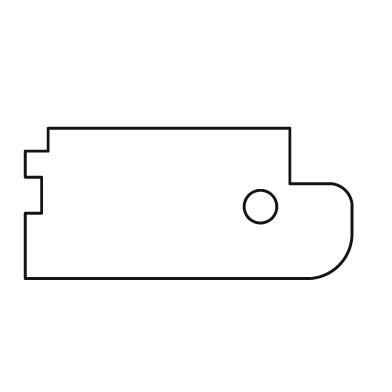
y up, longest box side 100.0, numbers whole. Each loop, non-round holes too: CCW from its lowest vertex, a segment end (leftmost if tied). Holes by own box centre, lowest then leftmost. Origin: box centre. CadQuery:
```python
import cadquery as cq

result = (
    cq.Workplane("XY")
    .moveTo(-50.0, -23.0)
    .lineTo(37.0, -23.0)
    .threePointArc((46.0, -19.0), (50.0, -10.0))
    .lineTo(50.0, 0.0)
    .threePointArc((48.0, 4.0), (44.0, 6.0))
    .lineTo(31.0, 6.0)
    .lineTo(31.0, 23.0)
    .lineTo(-43.0, 23.0)
    .lineTo(-43.0, 16.0)
    .lineTo(-50.0, 16.0)
    .lineTo(-50.0, 8.0)
    .lineTo(-45.0, 8.0)
    .lineTo(-45.0, -3.0)
    .lineTo(-50.0, -3.0)
    .close()
    .moveTo(22.0, -1.0)
    .circle(5.0)
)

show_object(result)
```